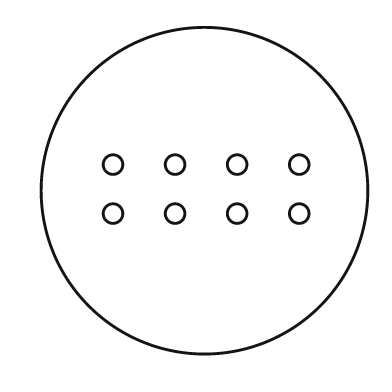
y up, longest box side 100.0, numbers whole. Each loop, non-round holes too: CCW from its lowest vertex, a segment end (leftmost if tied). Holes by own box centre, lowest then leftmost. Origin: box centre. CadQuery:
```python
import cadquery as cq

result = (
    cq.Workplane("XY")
    .moveTo(0.0, 0.0)
    .circle(50.0)
    .moveTo(-28.0, -7.0)
    .circle(3.0)
    .moveTo(-9.0, -7.0)
    .circle(3.0)
    .moveTo(10.0, -7.0)
    .circle(3.0)
    .moveTo(29.0, -7.0)
    .circle(3.0)
    .moveTo(-28.0, 8.0)
    .circle(3.0)
    .moveTo(-9.0, 8.0)
    .circle(3.0)
    .moveTo(10.0, 8.0)
    .circle(3.0)
    .moveTo(29.0, 8.0)
    .circle(3.0)
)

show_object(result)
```